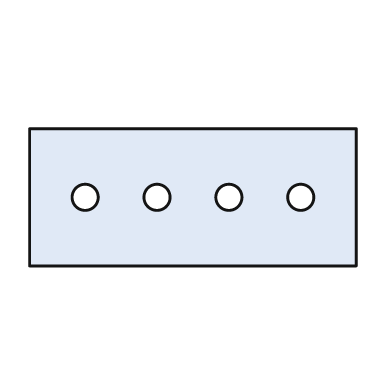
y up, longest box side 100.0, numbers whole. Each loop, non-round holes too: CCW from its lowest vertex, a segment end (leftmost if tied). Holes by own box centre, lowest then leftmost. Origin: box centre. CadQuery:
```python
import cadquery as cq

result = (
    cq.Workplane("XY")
    .moveTo(-50.0, -21.0)
    .lineTo(50.0, -21.0)
    .lineTo(50.0, 21.0)
    .lineTo(-50.0, 21.0)
    .close()
    .moveTo(-33.0, 0.0)
    .circle(4.0)
    .moveTo(-11.0, 0.0)
    .circle(4.0)
    .moveTo(11.0, 0.0)
    .circle(4.0)
    .moveTo(33.0, 0.0)
    .circle(4.0)
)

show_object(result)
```